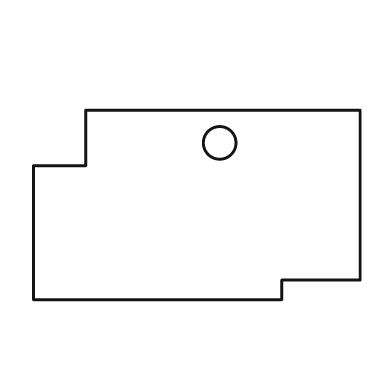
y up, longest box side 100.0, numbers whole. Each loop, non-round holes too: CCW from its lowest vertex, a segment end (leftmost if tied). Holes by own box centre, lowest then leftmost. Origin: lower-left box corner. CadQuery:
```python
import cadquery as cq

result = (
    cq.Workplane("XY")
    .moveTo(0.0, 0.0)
    .lineTo(76.0, 0.0)
    .lineTo(76.0, 6.0)
    .lineTo(100.0, 6.0)
    .lineTo(100.0, 58.0)
    .lineTo(16.0, 58.0)
    .lineTo(16.0, 41.0)
    .lineTo(0.0, 41.0)
    .close()
    .moveTo(57.0, 48.0)
    .circle(5.0)
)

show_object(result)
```